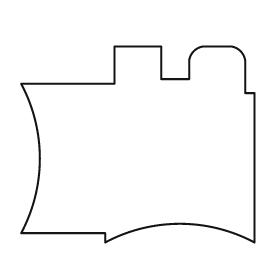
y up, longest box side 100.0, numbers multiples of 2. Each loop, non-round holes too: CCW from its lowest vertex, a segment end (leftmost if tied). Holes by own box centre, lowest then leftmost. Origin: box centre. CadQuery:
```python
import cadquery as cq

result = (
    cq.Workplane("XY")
    .moveTo(-14.0, -42.0)
    .threePointArc((18.0, -34.0), (50.0, -42.0))
    .lineTo(50.0, 22.0)
    .lineTo(46.0, 22.0)
    .lineTo(46.0, 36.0)
    .threePointArc((44.0, 40.0), (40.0, 42.0))
    .lineTo(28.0, 42.0)
    .threePointArc((24.0, 40.0), (22.0, 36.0))
    .lineTo(22.0, 28.0)
    .lineTo(10.0, 28.0)
    .lineTo(10.0, 42.0)
    .lineTo(-10.0, 42.0)
    .lineTo(-10.0, 26.0)
    .lineTo(-50.0, 26.0)
    .threePointArc((-42.0, -6.0), (-50.0, -38.0))
    .lineTo(-14.0, -38.0)
    .close()
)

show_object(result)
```